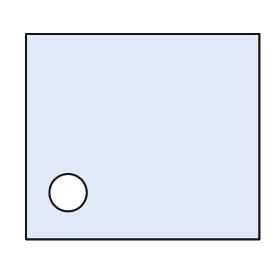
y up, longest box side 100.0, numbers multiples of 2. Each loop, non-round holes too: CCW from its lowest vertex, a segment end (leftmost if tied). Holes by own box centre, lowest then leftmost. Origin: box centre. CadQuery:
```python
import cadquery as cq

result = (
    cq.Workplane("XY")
    .moveTo(-50.0, -44.0)
    .lineTo(50.0, -44.0)
    .lineTo(50.0, 44.0)
    .lineTo(-50.0, 44.0)
    .close()
    .moveTo(-32.0, -24.0)
    .circle(8.0)
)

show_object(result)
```